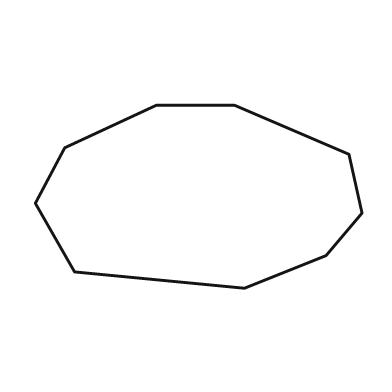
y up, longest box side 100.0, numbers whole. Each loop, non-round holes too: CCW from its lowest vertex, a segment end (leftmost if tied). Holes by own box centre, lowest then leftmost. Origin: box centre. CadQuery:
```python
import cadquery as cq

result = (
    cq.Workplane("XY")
    .moveTo(14.0, -28.0)
    .lineTo(39.0, -18.0)
    .lineTo(50.0, -5.0)
    .lineTo(46.0, 13.0)
    .lineTo(11.0, 28.0)
    .lineTo(-13.0, 28.0)
    .lineTo(-41.0, 15.0)
    .lineTo(-50.0, -2.0)
    .lineTo(-38.0, -23.0)
    .close()
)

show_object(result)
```